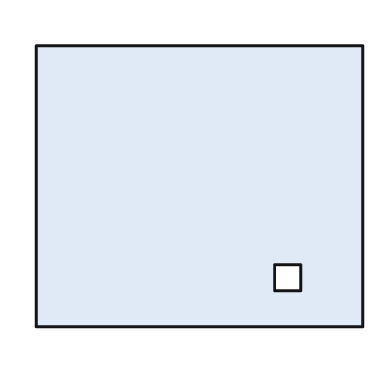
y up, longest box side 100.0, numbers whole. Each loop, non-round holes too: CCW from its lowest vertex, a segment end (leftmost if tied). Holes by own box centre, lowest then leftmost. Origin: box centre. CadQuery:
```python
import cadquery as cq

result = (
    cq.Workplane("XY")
    .moveTo(-50.0, -43.0)
    .lineTo(50.0, -43.0)
    .lineTo(50.0, 43.0)
    .lineTo(-50.0, 43.0)
    .close()
    .moveTo(23.0, -32.0)
    .lineTo(31.0, -32.0)
    .lineTo(31.0, -24.0)
    .lineTo(23.0, -24.0)
    .close()
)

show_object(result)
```